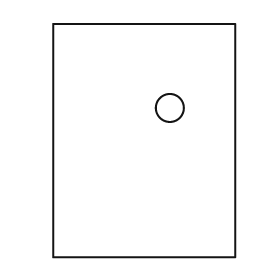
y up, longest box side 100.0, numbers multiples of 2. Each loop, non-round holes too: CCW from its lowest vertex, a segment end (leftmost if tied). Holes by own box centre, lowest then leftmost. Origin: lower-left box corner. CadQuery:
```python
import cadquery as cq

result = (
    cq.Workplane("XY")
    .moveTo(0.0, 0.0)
    .lineTo(78.0, 0.0)
    .lineTo(78.0, 100.0)
    .lineTo(0.0, 100.0)
    .close()
    .moveTo(50.0, 64.0)
    .circle(6.0)
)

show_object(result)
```